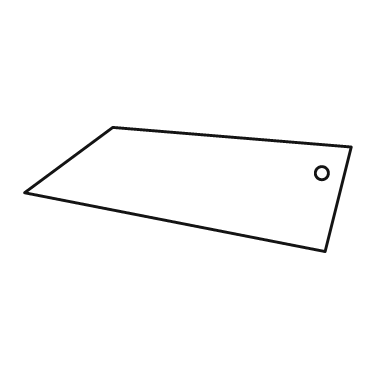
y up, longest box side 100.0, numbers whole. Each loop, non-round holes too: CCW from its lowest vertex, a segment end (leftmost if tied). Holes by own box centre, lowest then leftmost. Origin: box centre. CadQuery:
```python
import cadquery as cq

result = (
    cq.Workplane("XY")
    .moveTo(42.0, -19.0)
    .lineTo(50.0, 13.0)
    .lineTo(-23.0, 19.0)
    .lineTo(-50.0, -1.0)
    .close()
    .moveTo(41.0, 5.0)
    .circle(2.0)
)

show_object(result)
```